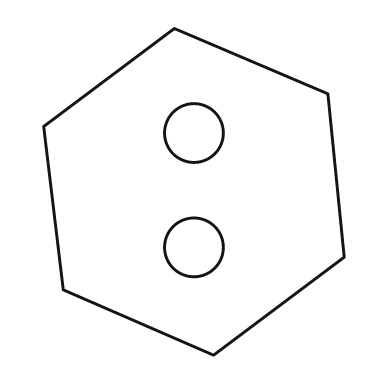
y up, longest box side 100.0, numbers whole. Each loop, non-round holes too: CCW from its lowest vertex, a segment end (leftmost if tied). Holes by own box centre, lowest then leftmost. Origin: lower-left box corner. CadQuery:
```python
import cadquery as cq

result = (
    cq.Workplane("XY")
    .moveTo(52.0, 0.0)
    .lineTo(92.0, 30.0)
    .lineTo(87.0, 80.0)
    .lineTo(40.0, 100.0)
    .lineTo(0.0, 70.0)
    .lineTo(6.0, 20.0)
    .close()
    .moveTo(46.0, 33.0)
    .circle(9.0)
    .moveTo(46.0, 68.0)
    .circle(9.0)
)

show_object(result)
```